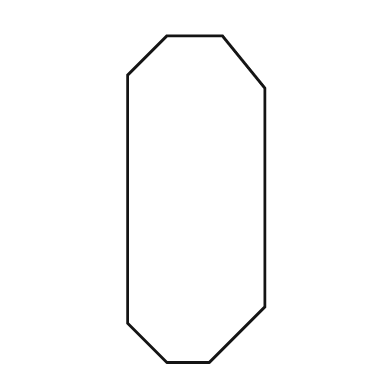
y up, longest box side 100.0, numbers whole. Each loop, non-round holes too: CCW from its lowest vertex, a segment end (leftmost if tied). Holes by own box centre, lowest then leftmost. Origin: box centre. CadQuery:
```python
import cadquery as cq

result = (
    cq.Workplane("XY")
    .moveTo(-9.0, -50.0)
    .lineTo(4.0, -50.0)
    .lineTo(21.0, -33.0)
    .lineTo(21.0, 34.0)
    .lineTo(8.0, 50.0)
    .lineTo(-9.0, 50.0)
    .lineTo(-21.0, 38.0)
    .lineTo(-21.0, -38.0)
    .close()
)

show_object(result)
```